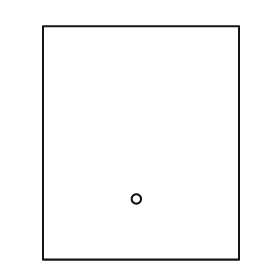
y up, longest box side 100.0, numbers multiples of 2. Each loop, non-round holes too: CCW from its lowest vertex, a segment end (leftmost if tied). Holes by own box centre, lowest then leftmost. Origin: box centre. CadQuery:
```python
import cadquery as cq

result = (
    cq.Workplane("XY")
    .moveTo(-42.0, -50.0)
    .lineTo(42.0, -50.0)
    .lineTo(42.0, 50.0)
    .lineTo(-42.0, 50.0)
    .close()
    .moveTo(-2.0, -24.0)
    .circle(2.0)
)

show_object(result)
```